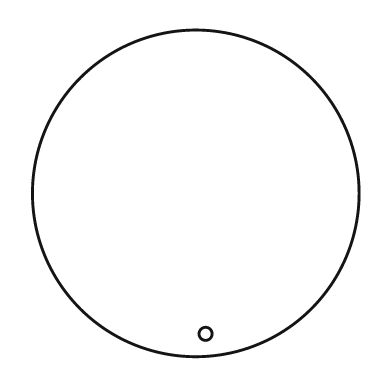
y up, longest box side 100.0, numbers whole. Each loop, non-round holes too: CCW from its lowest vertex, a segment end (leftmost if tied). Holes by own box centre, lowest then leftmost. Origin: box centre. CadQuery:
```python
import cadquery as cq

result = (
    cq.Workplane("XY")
    .moveTo(0.0, 0.0)
    .circle(50.0)
    .moveTo(3.0, -43.0)
    .circle(2.0)
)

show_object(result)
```